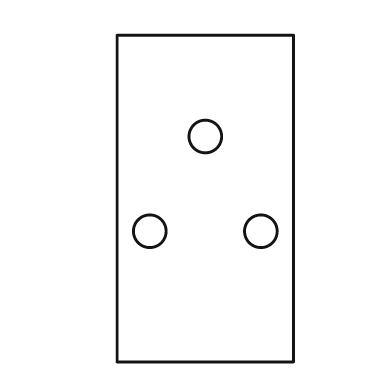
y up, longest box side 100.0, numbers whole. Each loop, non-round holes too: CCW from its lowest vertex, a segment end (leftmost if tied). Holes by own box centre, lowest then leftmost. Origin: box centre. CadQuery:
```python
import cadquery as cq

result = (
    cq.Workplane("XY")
    .moveTo(-27.0, -50.0)
    .lineTo(27.0, -50.0)
    .lineTo(27.0, 50.0)
    .lineTo(-27.0, 50.0)
    .close()
    .moveTo(-17.0, -10.0)
    .circle(5.0)
    .moveTo(17.0, -10.0)
    .circle(5.0)
    .moveTo(0.0, 19.0)
    .circle(5.0)
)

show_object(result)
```